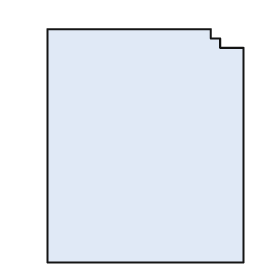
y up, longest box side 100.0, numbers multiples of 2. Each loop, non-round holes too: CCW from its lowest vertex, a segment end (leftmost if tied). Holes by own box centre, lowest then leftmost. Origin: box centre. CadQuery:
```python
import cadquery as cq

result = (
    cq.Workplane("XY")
    .moveTo(-42.0, -50.0)
    .lineTo(42.0, -50.0)
    .lineTo(42.0, 42.0)
    .lineTo(32.0, 42.0)
    .lineTo(32.0, 46.0)
    .lineTo(28.0, 46.0)
    .lineTo(28.0, 50.0)
    .lineTo(-42.0, 50.0)
    .close()
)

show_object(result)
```